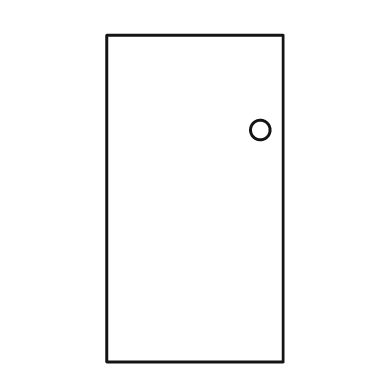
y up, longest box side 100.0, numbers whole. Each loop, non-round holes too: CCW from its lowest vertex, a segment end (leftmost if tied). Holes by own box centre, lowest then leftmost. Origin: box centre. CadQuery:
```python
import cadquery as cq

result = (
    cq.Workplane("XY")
    .moveTo(-27.0, -50.0)
    .lineTo(27.0, -50.0)
    .lineTo(27.0, 50.0)
    .lineTo(-27.0, 50.0)
    .close()
    .moveTo(20.0, 21.0)
    .circle(3.0)
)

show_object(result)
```